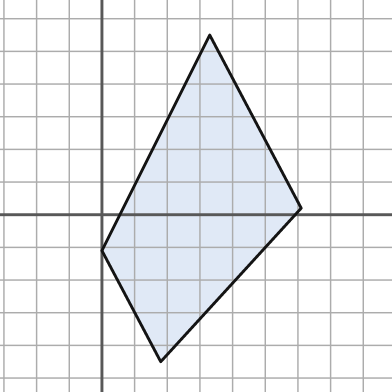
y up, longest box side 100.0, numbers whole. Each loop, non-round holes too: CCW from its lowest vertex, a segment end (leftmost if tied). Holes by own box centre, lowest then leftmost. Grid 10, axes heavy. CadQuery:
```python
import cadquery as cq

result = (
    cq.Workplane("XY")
    .moveTo(18.0, -45.0)
    .lineTo(61.0, 2.0)
    .lineTo(33.0, 55.0)
    .lineTo(0.0, -11.0)
    .close()
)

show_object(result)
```